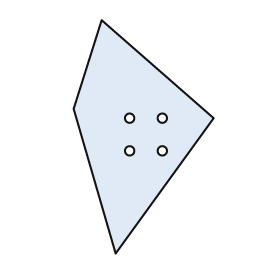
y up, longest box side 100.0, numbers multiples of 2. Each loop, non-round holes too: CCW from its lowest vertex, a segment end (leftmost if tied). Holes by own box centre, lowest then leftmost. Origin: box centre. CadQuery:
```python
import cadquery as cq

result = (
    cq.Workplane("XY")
    .moveTo(-12.0, -50.0)
    .lineTo(30.0, 8.0)
    .lineTo(-18.0, 50.0)
    .lineTo(-30.0, 12.0)
    .close()
    .moveTo(-6.0, -6.0)
    .circle(2.0)
    .moveTo(8.0, -6.0)
    .circle(2.0)
    .moveTo(-6.0, 8.0)
    .circle(2.0)
    .moveTo(8.0, 8.0)
    .circle(2.0)
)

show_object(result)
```